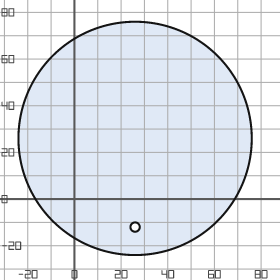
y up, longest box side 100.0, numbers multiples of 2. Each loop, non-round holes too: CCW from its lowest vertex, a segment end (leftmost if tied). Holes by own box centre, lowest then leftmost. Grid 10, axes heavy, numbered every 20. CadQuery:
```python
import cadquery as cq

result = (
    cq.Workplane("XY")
    .moveTo(26.0, 26.0)
    .circle(50.0)
    .moveTo(26.0, -12.0)
    .circle(2.0)
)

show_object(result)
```